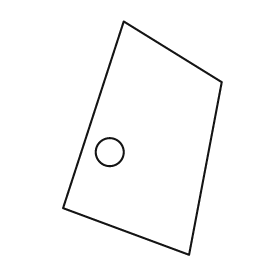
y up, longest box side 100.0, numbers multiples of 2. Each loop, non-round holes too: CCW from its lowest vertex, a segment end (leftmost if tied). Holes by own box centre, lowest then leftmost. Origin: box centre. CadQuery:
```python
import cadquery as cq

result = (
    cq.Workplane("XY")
    .moveTo(20.0, -50.0)
    .lineTo(34.0, 24.0)
    .lineTo(-8.0, 50.0)
    .lineTo(-34.0, -30.0)
    .close()
    .moveTo(-14.0, -6.0)
    .circle(6.0)
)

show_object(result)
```